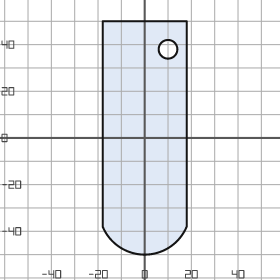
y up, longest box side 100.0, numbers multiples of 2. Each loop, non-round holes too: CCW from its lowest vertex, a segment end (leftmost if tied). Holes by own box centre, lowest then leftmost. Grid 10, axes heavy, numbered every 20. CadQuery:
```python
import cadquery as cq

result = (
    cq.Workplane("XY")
    .moveTo(-18.0, -38.0)
    .threePointArc((0.0, -50.0), (18.0, -38.0))
    .lineTo(18.0, 50.0)
    .lineTo(-18.0, 50.0)
    .close()
    .moveTo(10.0, 38.0)
    .circle(4.0)
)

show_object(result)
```